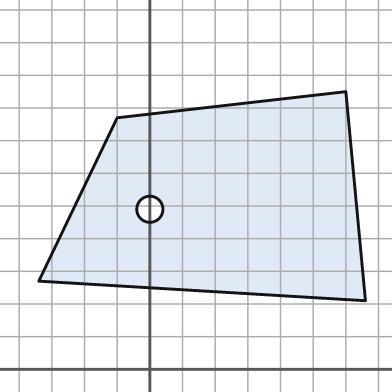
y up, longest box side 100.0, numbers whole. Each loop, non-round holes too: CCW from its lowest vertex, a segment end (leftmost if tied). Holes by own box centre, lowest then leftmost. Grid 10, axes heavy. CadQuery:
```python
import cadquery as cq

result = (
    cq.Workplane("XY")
    .moveTo(66.0, 21.0)
    .lineTo(60.0, 85.0)
    .lineTo(-10.0, 77.0)
    .lineTo(-34.0, 27.0)
    .close()
    .moveTo(0.0, 49.0)
    .circle(4.0)
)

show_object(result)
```